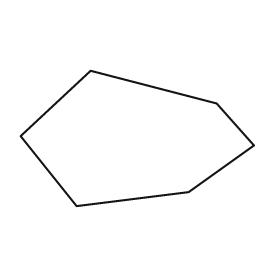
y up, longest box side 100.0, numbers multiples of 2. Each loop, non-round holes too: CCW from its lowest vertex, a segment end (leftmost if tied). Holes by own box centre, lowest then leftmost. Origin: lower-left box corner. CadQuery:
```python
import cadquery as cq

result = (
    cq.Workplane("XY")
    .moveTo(24.0, 0.0)
    .lineTo(72.0, 6.0)
    .lineTo(100.0, 26.0)
    .lineTo(84.0, 44.0)
    .lineTo(30.0, 58.0)
    .lineTo(0.0, 30.0)
    .close()
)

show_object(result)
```